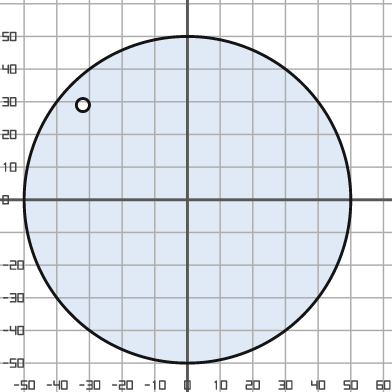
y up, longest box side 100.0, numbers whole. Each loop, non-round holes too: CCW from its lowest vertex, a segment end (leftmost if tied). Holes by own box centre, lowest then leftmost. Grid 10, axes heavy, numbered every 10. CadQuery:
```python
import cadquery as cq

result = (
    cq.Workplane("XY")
    .moveTo(0.0, 0.0)
    .circle(50.0)
    .moveTo(-32.0, 29.0)
    .circle(2.0)
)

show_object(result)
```